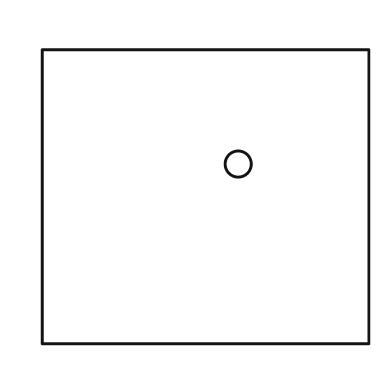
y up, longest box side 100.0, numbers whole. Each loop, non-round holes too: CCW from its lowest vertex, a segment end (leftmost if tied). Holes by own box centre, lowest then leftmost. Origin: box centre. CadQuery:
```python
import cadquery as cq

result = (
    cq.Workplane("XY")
    .moveTo(-50.0, -45.0)
    .lineTo(50.0, -45.0)
    .lineTo(50.0, 45.0)
    .lineTo(-50.0, 45.0)
    .close()
    .moveTo(10.0, 10.0)
    .circle(4.0)
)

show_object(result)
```